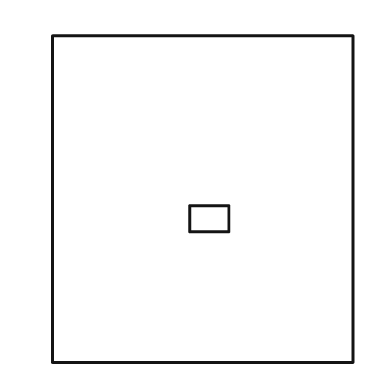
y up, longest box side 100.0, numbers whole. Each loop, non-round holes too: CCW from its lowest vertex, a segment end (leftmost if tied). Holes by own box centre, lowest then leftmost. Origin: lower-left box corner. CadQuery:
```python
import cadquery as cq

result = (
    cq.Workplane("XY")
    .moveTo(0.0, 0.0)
    .lineTo(92.0, 0.0)
    .lineTo(92.0, 100.0)
    .lineTo(0.0, 100.0)
    .close()
    .moveTo(42.0, 40.0)
    .lineTo(54.0, 40.0)
    .lineTo(54.0, 48.0)
    .lineTo(42.0, 48.0)
    .close()
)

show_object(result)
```